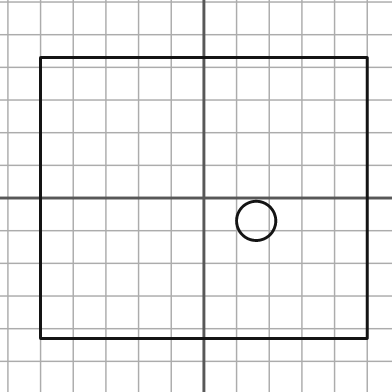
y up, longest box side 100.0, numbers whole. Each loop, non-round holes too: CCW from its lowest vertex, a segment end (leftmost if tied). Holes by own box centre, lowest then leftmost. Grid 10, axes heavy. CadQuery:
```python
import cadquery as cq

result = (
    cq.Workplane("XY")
    .moveTo(-50.0, -43.0)
    .lineTo(50.0, -43.0)
    .lineTo(50.0, 43.0)
    .lineTo(-50.0, 43.0)
    .close()
    .moveTo(16.0, -7.0)
    .circle(6.0)
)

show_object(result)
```